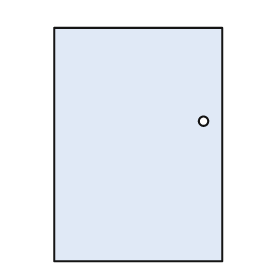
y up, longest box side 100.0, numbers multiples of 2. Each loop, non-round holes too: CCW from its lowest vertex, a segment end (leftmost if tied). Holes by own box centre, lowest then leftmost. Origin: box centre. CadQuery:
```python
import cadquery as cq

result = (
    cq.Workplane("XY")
    .moveTo(-36.0, -50.0)
    .lineTo(36.0, -50.0)
    .lineTo(36.0, 50.0)
    .lineTo(-36.0, 50.0)
    .close()
    .moveTo(28.0, 10.0)
    .circle(2.0)
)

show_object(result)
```